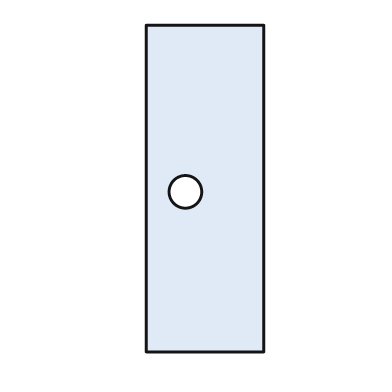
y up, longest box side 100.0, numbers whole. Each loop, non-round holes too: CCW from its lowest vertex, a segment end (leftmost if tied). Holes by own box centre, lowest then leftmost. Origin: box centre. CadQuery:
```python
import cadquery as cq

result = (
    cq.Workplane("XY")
    .moveTo(-18.0, -50.0)
    .lineTo(18.0, -50.0)
    .lineTo(18.0, 50.0)
    .lineTo(-18.0, 50.0)
    .close()
    .moveTo(-6.0, -1.0)
    .circle(5.0)
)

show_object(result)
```